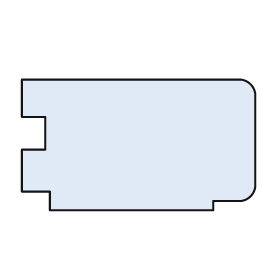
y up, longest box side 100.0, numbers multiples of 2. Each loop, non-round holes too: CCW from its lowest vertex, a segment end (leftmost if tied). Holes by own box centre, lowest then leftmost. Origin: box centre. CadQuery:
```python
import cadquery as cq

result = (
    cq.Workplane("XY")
    .moveTo(-38.0, -28.0)
    .lineTo(32.0, -28.0)
    .lineTo(32.0, -24.0)
    .lineTo(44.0, -24.0)
    .threePointArc((48.0, -22.0), (50.0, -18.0))
    .lineTo(50.0, 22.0)
    .threePointArc((48.0, 26.0), (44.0, 28.0))
    .lineTo(-50.0, 28.0)
    .lineTo(-50.0, 12.0)
    .lineTo(-40.0, 12.0)
    .lineTo(-40.0, -2.0)
    .lineTo(-50.0, -2.0)
    .lineTo(-50.0, -20.0)
    .lineTo(-38.0, -20.0)
    .close()
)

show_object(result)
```